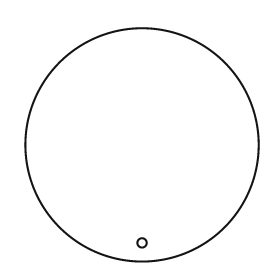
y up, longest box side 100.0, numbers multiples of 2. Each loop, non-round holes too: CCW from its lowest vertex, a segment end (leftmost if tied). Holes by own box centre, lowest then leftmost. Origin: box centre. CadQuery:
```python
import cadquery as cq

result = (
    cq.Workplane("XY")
    .moveTo(0.0, 0.0)
    .circle(50.0)
    .moveTo(0.0, -42.0)
    .circle(2.0)
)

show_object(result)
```